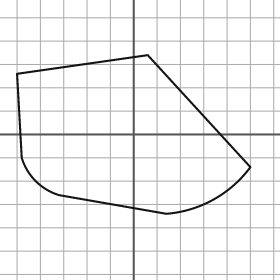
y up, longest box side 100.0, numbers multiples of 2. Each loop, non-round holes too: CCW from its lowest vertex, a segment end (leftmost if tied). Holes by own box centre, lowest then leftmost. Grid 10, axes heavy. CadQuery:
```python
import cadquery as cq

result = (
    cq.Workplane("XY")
    .moveTo(14.0, -34.0)
    .threePointArc((34.0, -28.0), (50.0, -14.0))
    .lineTo(6.0, 34.0)
    .lineTo(-50.0, 26.0)
    .lineTo(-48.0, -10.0)
    .threePointArc((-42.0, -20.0), (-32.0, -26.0))
    .close()
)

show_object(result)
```